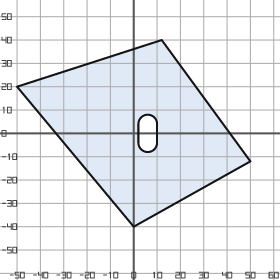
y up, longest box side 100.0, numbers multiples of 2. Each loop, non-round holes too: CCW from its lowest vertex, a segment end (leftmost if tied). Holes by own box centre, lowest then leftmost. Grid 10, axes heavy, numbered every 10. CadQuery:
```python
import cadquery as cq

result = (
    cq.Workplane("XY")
    .moveTo(0.0, -40.0)
    .lineTo(50.0, -12.0)
    .lineTo(12.0, 40.0)
    .lineTo(-50.0, 20.0)
    .close()
    .moveTo(2.0, -4.0)
    .threePointArc((6.0, -8.0), (10.0, -4.0))
    .lineTo(10.0, 4.0)
    .threePointArc((6.0, 8.0), (2.0, 4.0))
    .close()
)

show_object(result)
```